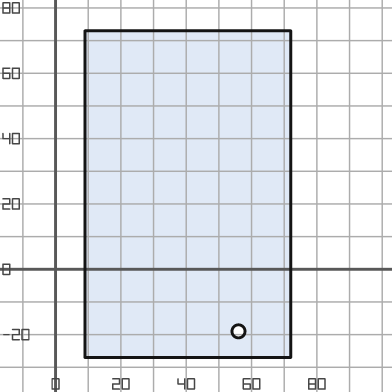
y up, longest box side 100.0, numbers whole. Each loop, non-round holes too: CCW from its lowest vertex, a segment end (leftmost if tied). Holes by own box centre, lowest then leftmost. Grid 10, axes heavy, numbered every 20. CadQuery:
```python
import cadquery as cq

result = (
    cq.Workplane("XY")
    .moveTo(9.0, -27.0)
    .lineTo(72.0, -27.0)
    .lineTo(72.0, 73.0)
    .lineTo(9.0, 73.0)
    .close()
    .moveTo(56.0, -19.0)
    .circle(2.0)
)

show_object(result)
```